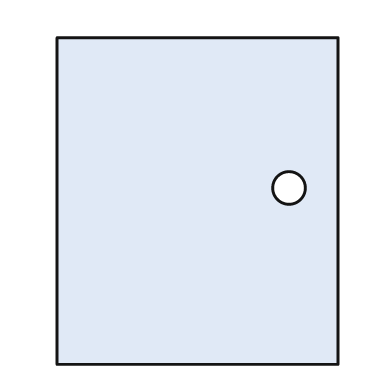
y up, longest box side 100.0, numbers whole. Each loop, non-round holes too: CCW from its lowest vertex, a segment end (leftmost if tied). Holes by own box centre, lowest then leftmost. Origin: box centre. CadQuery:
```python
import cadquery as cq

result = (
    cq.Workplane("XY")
    .moveTo(-43.0, -50.0)
    .lineTo(43.0, -50.0)
    .lineTo(43.0, 50.0)
    .lineTo(-43.0, 50.0)
    .close()
    .moveTo(28.0, 4.0)
    .circle(5.0)
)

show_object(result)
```